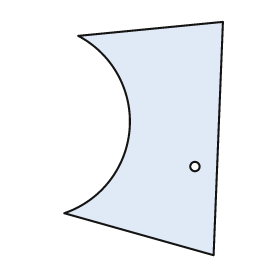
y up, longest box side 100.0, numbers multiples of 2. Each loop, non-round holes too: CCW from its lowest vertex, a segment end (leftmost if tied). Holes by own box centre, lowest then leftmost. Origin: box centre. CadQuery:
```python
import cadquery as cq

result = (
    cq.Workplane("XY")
    .moveTo(30.0, -50.0)
    .lineTo(34.0, 50.0)
    .lineTo(-28.0, 44.0)
    .threePointArc((-6.0, 4.0), (-34.0, -32.0))
    .close()
    .moveTo(22.0, -12.0)
    .circle(2.0)
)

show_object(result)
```